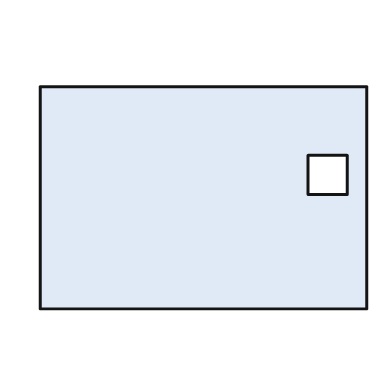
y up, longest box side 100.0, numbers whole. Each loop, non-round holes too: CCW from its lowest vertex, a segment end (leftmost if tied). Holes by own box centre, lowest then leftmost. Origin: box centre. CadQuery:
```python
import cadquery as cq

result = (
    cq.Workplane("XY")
    .moveTo(-50.0, -34.0)
    .lineTo(50.0, -34.0)
    .lineTo(50.0, 34.0)
    .lineTo(-50.0, 34.0)
    .close()
    .moveTo(32.0, 1.0)
    .lineTo(44.0, 1.0)
    .lineTo(44.0, 13.0)
    .lineTo(32.0, 13.0)
    .close()
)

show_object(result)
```